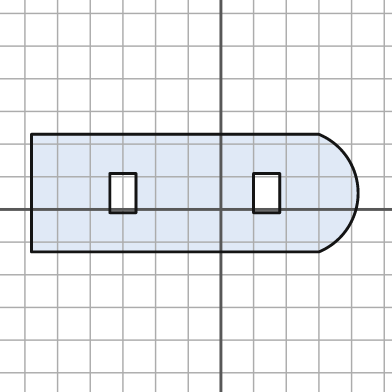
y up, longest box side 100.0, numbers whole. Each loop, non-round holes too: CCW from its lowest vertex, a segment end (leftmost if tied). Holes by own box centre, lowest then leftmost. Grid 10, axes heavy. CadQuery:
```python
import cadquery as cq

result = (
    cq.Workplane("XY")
    .moveTo(-58.0, -13.0)
    .lineTo(30.0, -13.0)
    .threePointArc((42.0, 5.0), (30.0, 23.0))
    .lineTo(-58.0, 23.0)
    .close()
    .moveTo(-34.0, -1.0)
    .lineTo(-26.0, -1.0)
    .lineTo(-26.0, 11.0)
    .lineTo(-34.0, 11.0)
    .close()
    .moveTo(10.0, -1.0)
    .lineTo(18.0, -1.0)
    .lineTo(18.0, 11.0)
    .lineTo(10.0, 11.0)
    .close()
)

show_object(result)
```